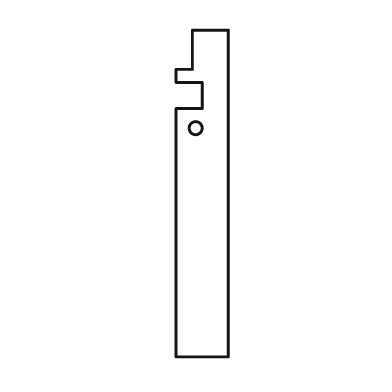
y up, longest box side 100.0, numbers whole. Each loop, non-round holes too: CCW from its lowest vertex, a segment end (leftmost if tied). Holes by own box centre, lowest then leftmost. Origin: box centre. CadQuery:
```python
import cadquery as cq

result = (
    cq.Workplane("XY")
    .moveTo(-8.0, -50.0)
    .lineTo(8.0, -50.0)
    .lineTo(8.0, 50.0)
    .lineTo(-3.0, 50.0)
    .lineTo(-3.0, 38.0)
    .lineTo(-8.0, 38.0)
    .lineTo(-8.0, 34.0)
    .lineTo(0.0, 34.0)
    .lineTo(0.0, 26.0)
    .lineTo(-8.0, 26.0)
    .close()
    .moveTo(-2.0, 20.0)
    .circle(2.0)
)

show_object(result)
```